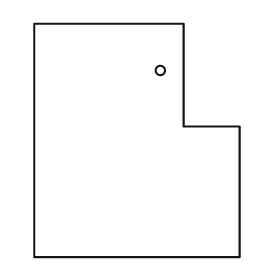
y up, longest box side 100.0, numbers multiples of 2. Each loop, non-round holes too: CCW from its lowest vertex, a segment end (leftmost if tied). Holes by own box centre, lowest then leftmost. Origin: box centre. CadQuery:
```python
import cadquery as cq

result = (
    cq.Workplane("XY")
    .moveTo(-44.0, -50.0)
    .lineTo(44.0, -50.0)
    .lineTo(44.0, 6.0)
    .lineTo(20.0, 6.0)
    .lineTo(20.0, 50.0)
    .lineTo(-44.0, 50.0)
    .close()
    .moveTo(10.0, 30.0)
    .circle(2.0)
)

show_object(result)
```